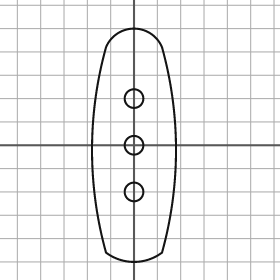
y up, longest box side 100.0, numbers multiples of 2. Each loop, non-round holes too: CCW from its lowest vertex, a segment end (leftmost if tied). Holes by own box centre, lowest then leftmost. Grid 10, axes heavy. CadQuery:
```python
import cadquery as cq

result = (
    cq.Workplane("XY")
    .moveTo(-12.0, -46.0)
    .threePointArc((0.0, -50.0), (12.0, -46.0))
    .threePointArc((18.0, -2.0), (12.0, 42.0))
    .threePointArc((0.0, 50.0), (-12.0, 42.0))
    .threePointArc((-18.0, -2.0), (-12.0, -46.0))
    .close()
    .moveTo(0.0, -20.0)
    .circle(4.0)
    .moveTo(0.0, 0.0)
    .circle(4.0)
    .moveTo(0.0, 20.0)
    .circle(4.0)
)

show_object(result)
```